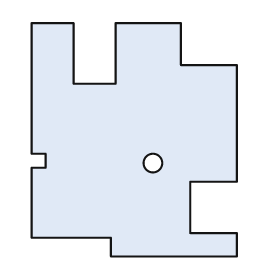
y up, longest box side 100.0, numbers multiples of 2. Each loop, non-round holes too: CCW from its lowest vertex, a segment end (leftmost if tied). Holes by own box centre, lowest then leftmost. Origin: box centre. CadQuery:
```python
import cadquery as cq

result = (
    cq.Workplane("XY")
    .moveTo(-10.0, -50.0)
    .lineTo(44.0, -50.0)
    .lineTo(44.0, -40.0)
    .lineTo(24.0, -40.0)
    .lineTo(24.0, -18.0)
    .lineTo(44.0, -18.0)
    .lineTo(44.0, 32.0)
    .lineTo(20.0, 32.0)
    .lineTo(20.0, 50.0)
    .lineTo(-8.0, 50.0)
    .lineTo(-8.0, 24.0)
    .lineTo(-26.0, 24.0)
    .lineTo(-26.0, 50.0)
    .lineTo(-44.0, 50.0)
    .lineTo(-44.0, -6.0)
    .lineTo(-38.0, -6.0)
    .lineTo(-38.0, -12.0)
    .lineTo(-44.0, -12.0)
    .lineTo(-44.0, -42.0)
    .lineTo(-10.0, -42.0)
    .close()
    .moveTo(8.0, -10.0)
    .circle(4.0)
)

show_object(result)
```